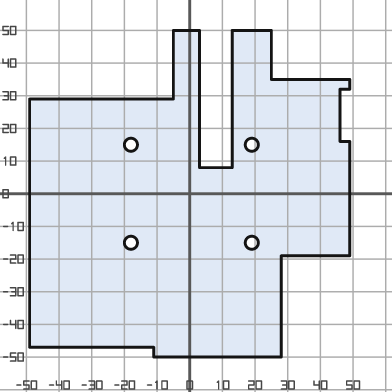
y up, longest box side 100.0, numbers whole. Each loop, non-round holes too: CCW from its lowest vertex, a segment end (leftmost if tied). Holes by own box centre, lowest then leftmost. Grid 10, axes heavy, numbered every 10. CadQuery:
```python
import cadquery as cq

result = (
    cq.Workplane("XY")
    .moveTo(-11.0, -50.0)
    .lineTo(28.0, -50.0)
    .lineTo(28.0, -19.0)
    .lineTo(49.0, -19.0)
    .lineTo(49.0, 16.0)
    .lineTo(46.0, 16.0)
    .lineTo(46.0, 32.0)
    .lineTo(49.0, 32.0)
    .lineTo(49.0, 35.0)
    .lineTo(25.0, 35.0)
    .lineTo(25.0, 50.0)
    .lineTo(13.0, 50.0)
    .lineTo(13.0, 8.0)
    .lineTo(3.0, 8.0)
    .lineTo(3.0, 50.0)
    .lineTo(-5.0, 50.0)
    .lineTo(-5.0, 29.0)
    .lineTo(-49.0, 29.0)
    .lineTo(-49.0, -47.0)
    .lineTo(-11.0, -47.0)
    .close()
    .moveTo(-18.0, -15.0)
    .circle(2.0)
    .moveTo(19.0, -15.0)
    .circle(2.0)
    .moveTo(-18.0, 15.0)
    .circle(2.0)
    .moveTo(19.0, 15.0)
    .circle(2.0)
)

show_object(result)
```